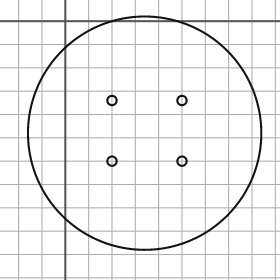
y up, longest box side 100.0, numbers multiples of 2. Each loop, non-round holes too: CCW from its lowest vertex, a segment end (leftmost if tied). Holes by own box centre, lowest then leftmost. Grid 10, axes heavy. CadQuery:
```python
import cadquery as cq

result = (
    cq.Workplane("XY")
    .moveTo(34.0, -48.0)
    .circle(50.0)
    .moveTo(20.0, -60.0)
    .circle(2.0)
    .moveTo(50.0, -60.0)
    .circle(2.0)
    .moveTo(20.0, -34.0)
    .circle(2.0)
    .moveTo(50.0, -34.0)
    .circle(2.0)
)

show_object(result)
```